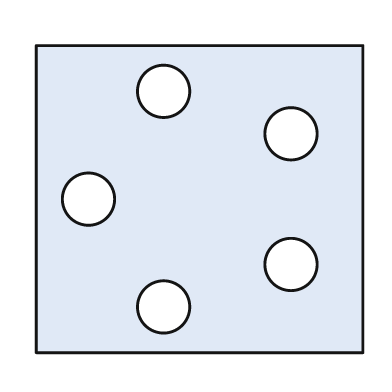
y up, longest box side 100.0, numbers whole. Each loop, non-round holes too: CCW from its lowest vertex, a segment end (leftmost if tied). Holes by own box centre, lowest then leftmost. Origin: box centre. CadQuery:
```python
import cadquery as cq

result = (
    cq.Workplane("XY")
    .moveTo(-50.0, -47.0)
    .lineTo(50.0, -47.0)
    .lineTo(50.0, 47.0)
    .lineTo(-50.0, 47.0)
    .close()
    .moveTo(-11.0, -33.0)
    .circle(8.0)
    .moveTo(28.0, -20.0)
    .circle(8.0)
    .moveTo(-34.0, 0.0)
    .circle(8.0)
    .moveTo(28.0, 20.0)
    .circle(8.0)
    .moveTo(-11.0, 33.0)
    .circle(8.0)
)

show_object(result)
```